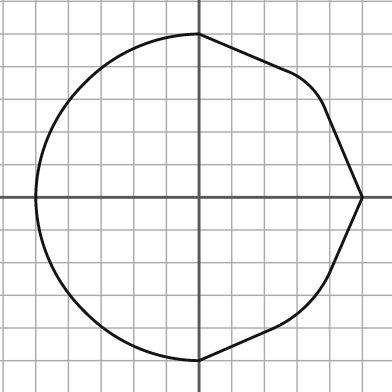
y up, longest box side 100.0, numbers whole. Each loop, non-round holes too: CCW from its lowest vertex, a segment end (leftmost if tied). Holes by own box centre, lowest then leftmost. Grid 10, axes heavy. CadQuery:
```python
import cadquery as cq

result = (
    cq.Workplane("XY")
    .moveTo(0.0, -50.0)
    .lineTo(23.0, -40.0)
    .threePointArc((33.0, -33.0), (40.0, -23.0))
    .lineTo(50.0, 0.0)
    .lineTo(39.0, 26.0)
    .threePointArc((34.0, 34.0), (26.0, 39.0))
    .lineTo(0.0, 50.0)
    .threePointArc((-19.0, 46.0), (-35.0, 35.0))
    .threePointArc((-46.0, 19.0), (-50.0, 0.0))
    .threePointArc((-46.0, -19.0), (-35.0, -35.0))
    .threePointArc((-19.0, -46.0), (0.0, -50.0))
    .close()
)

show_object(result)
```